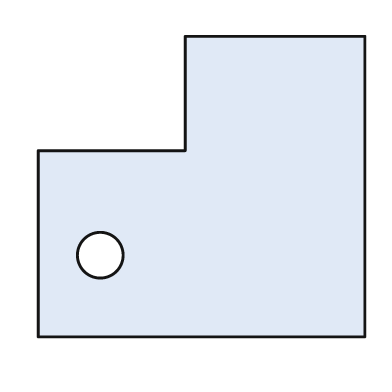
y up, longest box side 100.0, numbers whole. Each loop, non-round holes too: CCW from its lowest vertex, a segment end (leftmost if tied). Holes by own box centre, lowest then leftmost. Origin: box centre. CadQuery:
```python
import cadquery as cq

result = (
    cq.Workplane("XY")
    .moveTo(-50.0, -46.0)
    .lineTo(50.0, -46.0)
    .lineTo(50.0, 46.0)
    .lineTo(-5.0, 46.0)
    .lineTo(-5.0, 11.0)
    .lineTo(-50.0, 11.0)
    .close()
    .moveTo(-31.0, -21.0)
    .circle(7.0)
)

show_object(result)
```